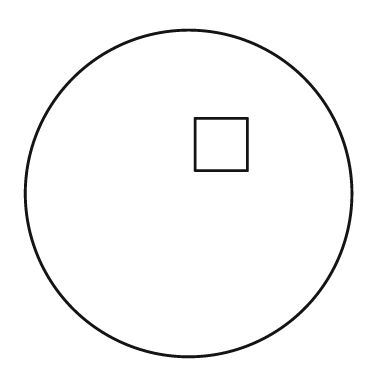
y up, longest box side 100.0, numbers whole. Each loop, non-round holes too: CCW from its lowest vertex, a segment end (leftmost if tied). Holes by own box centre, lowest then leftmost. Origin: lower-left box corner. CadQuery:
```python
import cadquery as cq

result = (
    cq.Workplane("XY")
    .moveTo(50.0, 50.0)
    .circle(50.0)
    .moveTo(52.0, 57.0)
    .lineTo(68.0, 57.0)
    .lineTo(68.0, 73.0)
    .lineTo(52.0, 73.0)
    .close()
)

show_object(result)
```